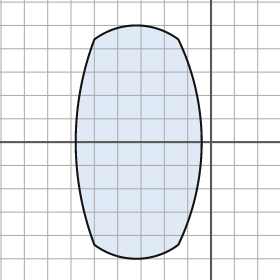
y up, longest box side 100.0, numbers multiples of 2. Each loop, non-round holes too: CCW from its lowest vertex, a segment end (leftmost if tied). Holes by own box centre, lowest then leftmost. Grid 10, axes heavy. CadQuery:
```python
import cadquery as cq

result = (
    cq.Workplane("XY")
    .moveTo(-50.0, -44.0)
    .threePointArc((-32.0, -50.0), (-14.0, -44.0))
    .threePointArc((-4.0, 0.0), (-14.0, 44.0))
    .threePointArc((-32.0, 50.0), (-50.0, 44.0))
    .threePointArc((-58.0, 0.0), (-50.0, -44.0))
    .close()
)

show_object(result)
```